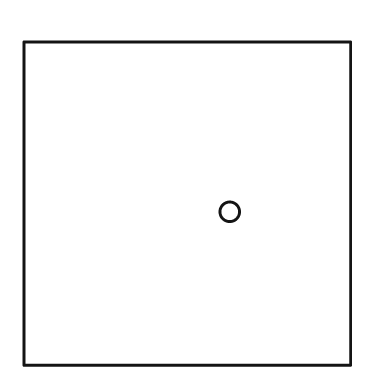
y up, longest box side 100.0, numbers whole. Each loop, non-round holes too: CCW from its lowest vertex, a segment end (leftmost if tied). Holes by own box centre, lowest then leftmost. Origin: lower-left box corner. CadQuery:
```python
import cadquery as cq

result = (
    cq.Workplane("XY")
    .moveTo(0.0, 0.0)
    .lineTo(100.0, 0.0)
    .lineTo(100.0, 99.0)
    .lineTo(0.0, 99.0)
    .close()
    .moveTo(63.0, 47.0)
    .circle(3.0)
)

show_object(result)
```